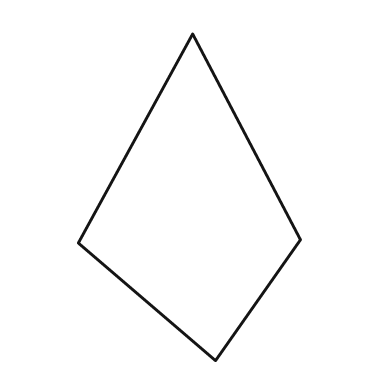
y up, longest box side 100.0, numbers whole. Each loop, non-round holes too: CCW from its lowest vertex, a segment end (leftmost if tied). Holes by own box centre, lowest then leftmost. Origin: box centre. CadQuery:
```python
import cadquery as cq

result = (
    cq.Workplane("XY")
    .moveTo(8.0, -50.0)
    .lineTo(34.0, -13.0)
    .lineTo(1.0, 50.0)
    .lineTo(-34.0, -14.0)
    .close()
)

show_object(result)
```